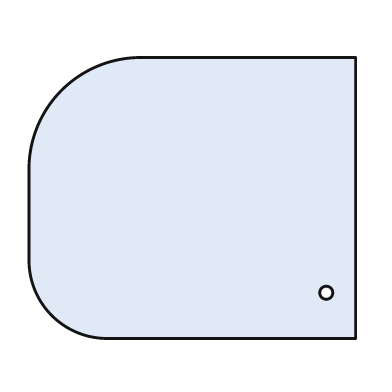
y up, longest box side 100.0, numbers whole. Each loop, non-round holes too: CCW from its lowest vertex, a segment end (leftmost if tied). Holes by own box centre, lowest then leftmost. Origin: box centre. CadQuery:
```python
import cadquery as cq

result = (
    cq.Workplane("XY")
    .moveTo(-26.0, -43.0)
    .lineTo(50.0, -43.0)
    .lineTo(50.0, 43.0)
    .lineTo(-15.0, 43.0)
    .threePointArc((-40.0, 33.0), (-50.0, 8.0))
    .lineTo(-50.0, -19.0)
    .threePointArc((-43.0, -36.0), (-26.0, -43.0))
    .close()
    .moveTo(41.0, -29.0)
    .circle(2.0)
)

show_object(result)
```